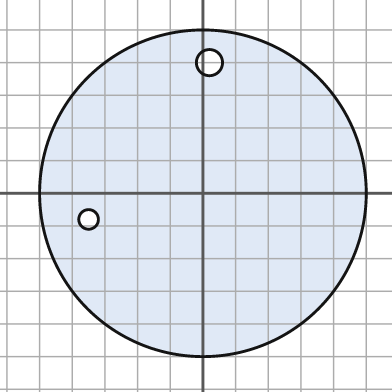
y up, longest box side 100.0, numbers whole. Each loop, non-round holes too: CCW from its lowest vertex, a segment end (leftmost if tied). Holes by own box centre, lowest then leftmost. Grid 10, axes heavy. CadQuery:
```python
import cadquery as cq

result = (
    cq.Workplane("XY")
    .moveTo(0.0, 0.0)
    .circle(50.0)
    .moveTo(-35.0, -8.0)
    .circle(3.0)
    .moveTo(2.0, 40.0)
    .circle(4.0)
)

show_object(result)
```